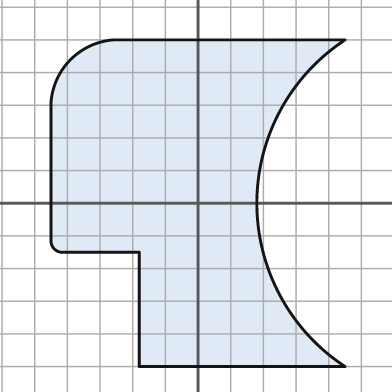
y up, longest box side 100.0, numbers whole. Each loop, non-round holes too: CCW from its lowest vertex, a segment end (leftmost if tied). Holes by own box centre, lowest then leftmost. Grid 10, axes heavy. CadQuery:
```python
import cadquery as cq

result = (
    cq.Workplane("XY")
    .moveTo(-18.0, -50.0)
    .lineTo(45.0, -50.0)
    .threePointArc((18.0, 0.0), (45.0, 50.0))
    .lineTo(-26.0, 50.0)
    .threePointArc((-39.0, 44.0), (-45.0, 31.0))
    .lineTo(-45.0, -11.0)
    .threePointArc((-44.0, -14.0), (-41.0, -15.0))
    .lineTo(-18.0, -15.0)
    .close()
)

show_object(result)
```